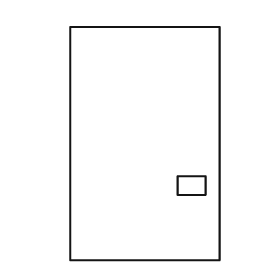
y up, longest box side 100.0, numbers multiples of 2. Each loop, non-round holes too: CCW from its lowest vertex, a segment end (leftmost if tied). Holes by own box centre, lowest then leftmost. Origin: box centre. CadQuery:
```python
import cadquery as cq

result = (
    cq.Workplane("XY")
    .moveTo(-32.0, -50.0)
    .lineTo(32.0, -50.0)
    .lineTo(32.0, 50.0)
    .lineTo(-32.0, 50.0)
    .close()
    .moveTo(14.0, -22.0)
    .lineTo(26.0, -22.0)
    .lineTo(26.0, -14.0)
    .lineTo(14.0, -14.0)
    .close()
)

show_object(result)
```